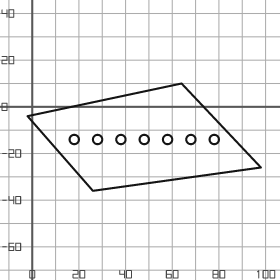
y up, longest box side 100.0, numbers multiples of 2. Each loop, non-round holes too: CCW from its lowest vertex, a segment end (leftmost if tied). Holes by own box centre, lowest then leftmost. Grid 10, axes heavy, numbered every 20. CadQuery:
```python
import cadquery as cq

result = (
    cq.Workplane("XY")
    .moveTo(26.0, -36.0)
    .lineTo(98.0, -26.0)
    .lineTo(64.0, 10.0)
    .lineTo(-2.0, -4.0)
    .close()
    .moveTo(18.0, -14.0)
    .circle(2.0)
    .moveTo(28.0, -14.0)
    .circle(2.0)
    .moveTo(38.0, -14.0)
    .circle(2.0)
    .moveTo(48.0, -14.0)
    .circle(2.0)
    .moveTo(58.0, -14.0)
    .circle(2.0)
    .moveTo(68.0, -14.0)
    .circle(2.0)
    .moveTo(78.0, -14.0)
    .circle(2.0)
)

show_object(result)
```